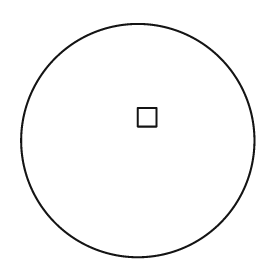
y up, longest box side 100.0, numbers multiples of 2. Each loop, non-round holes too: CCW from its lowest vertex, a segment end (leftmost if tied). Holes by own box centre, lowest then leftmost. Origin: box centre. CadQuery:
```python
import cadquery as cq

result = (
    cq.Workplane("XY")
    .moveTo(0.0, 0.0)
    .circle(50.0)
    .moveTo(0.0, 6.0)
    .lineTo(8.0, 6.0)
    .lineTo(8.0, 14.0)
    .lineTo(0.0, 14.0)
    .close()
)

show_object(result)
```